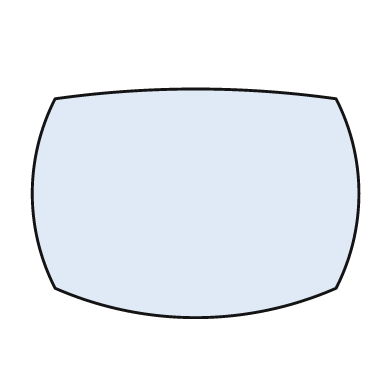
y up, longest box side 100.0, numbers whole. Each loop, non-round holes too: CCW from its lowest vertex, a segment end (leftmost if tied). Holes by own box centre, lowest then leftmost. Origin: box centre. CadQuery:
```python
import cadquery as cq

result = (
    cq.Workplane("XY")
    .moveTo(-43.0, -26.0)
    .threePointArc((0.0, -35.0), (43.0, -26.0))
    .threePointArc((50.0, 3.0), (43.0, 32.0))
    .threePointArc((0.0, 35.0), (-43.0, 32.0))
    .threePointArc((-50.0, 3.0), (-43.0, -26.0))
    .close()
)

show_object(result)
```